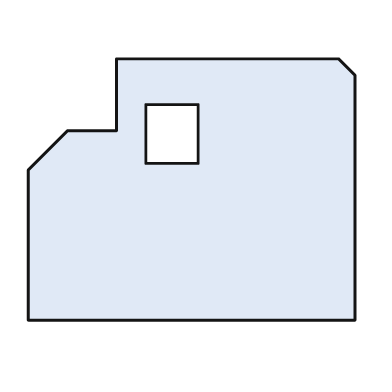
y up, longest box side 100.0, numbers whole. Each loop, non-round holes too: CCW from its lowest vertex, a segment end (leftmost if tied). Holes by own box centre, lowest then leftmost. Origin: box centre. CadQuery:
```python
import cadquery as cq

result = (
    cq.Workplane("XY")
    .moveTo(-50.0, -40.0)
    .lineTo(50.0, -40.0)
    .lineTo(50.0, 35.0)
    .lineTo(45.0, 40.0)
    .lineTo(-23.0, 40.0)
    .lineTo(-23.0, 18.0)
    .lineTo(-38.0, 18.0)
    .lineTo(-50.0, 6.0)
    .close()
    .moveTo(-14.0, 8.0)
    .lineTo(2.0, 8.0)
    .lineTo(2.0, 26.0)
    .lineTo(-14.0, 26.0)
    .close()
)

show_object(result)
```